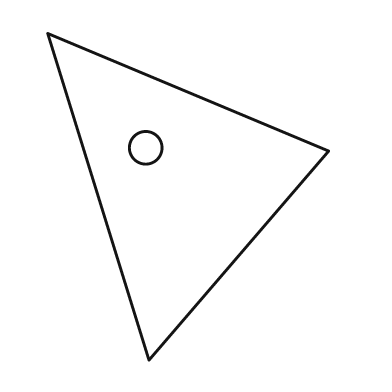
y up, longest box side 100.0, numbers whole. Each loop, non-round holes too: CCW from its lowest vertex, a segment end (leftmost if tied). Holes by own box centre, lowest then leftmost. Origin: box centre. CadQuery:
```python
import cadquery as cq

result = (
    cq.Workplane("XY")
    .moveTo(-12.0, -50.0)
    .lineTo(43.0, 14.0)
    .lineTo(-43.0, 50.0)
    .close()
    .moveTo(-13.0, 15.0)
    .circle(5.0)
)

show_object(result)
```